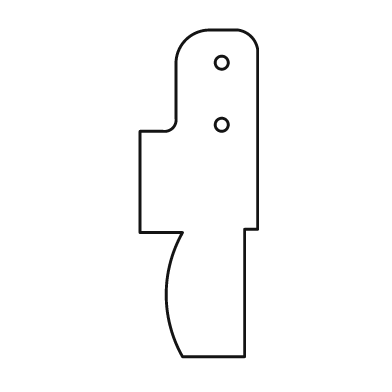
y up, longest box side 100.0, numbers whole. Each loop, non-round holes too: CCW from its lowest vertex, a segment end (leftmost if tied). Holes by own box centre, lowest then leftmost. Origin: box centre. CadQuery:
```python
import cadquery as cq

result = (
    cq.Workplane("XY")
    .moveTo(-5.0, -50.0)
    .lineTo(14.0, -50.0)
    .lineTo(14.0, -11.0)
    .lineTo(18.0, -11.0)
    .lineTo(18.0, 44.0)
    .threePointArc((16.0, 48.0), (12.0, 50.0))
    .lineTo(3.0, 50.0)
    .threePointArc((-4.0, 47.0), (-7.0, 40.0))
    .lineTo(-7.0, 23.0)
    .threePointArc((-8.0, 20.0), (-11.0, 19.0))
    .lineTo(-18.0, 19.0)
    .lineTo(-18.0, -12.0)
    .lineTo(-5.0, -12.0)
    .threePointArc((-10.0, -31.0), (-5.0, -50.0))
    .close()
    .moveTo(7.0, 21.0)
    .circle(2.0)
    .moveTo(7.0, 40.0)
    .circle(2.0)
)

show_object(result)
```